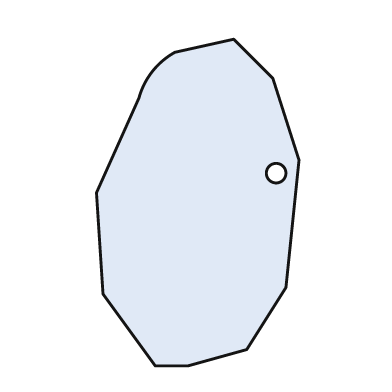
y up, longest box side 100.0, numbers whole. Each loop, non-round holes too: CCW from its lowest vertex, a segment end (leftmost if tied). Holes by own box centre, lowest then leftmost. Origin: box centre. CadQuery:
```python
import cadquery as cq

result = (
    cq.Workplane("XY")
    .moveTo(-13.0, -50.0)
    .lineTo(-3.0, -50.0)
    .lineTo(15.0, -45.0)
    .lineTo(27.0, -26.0)
    .lineTo(31.0, 13.0)
    .lineTo(23.0, 38.0)
    .lineTo(11.0, 50.0)
    .lineTo(-7.0, 46.0)
    .threePointArc((-14.0, 40.0), (-18.0, 32.0))
    .lineTo(-31.0, 3.0)
    .lineTo(-29.0, -28.0)
    .close()
    .moveTo(24.0, 9.0)
    .circle(3.0)
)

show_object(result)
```